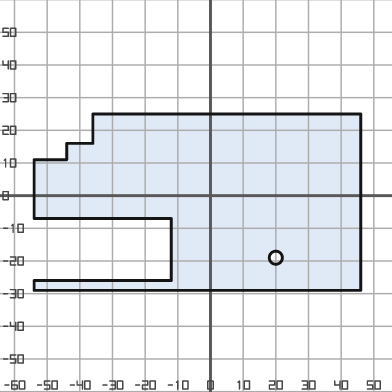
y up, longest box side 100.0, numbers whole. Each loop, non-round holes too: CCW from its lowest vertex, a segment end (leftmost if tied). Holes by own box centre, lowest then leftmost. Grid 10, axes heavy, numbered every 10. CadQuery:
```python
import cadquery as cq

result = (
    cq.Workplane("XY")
    .moveTo(-54.0, -29.0)
    .lineTo(46.0, -29.0)
    .lineTo(46.0, 25.0)
    .lineTo(-36.0, 25.0)
    .lineTo(-36.0, 16.0)
    .lineTo(-44.0, 16.0)
    .lineTo(-44.0, 11.0)
    .lineTo(-54.0, 11.0)
    .lineTo(-54.0, -7.0)
    .lineTo(-12.0, -7.0)
    .lineTo(-12.0, -26.0)
    .lineTo(-54.0, -26.0)
    .close()
    .moveTo(20.0, -19.0)
    .circle(2.0)
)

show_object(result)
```